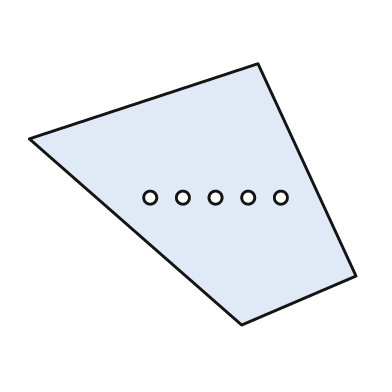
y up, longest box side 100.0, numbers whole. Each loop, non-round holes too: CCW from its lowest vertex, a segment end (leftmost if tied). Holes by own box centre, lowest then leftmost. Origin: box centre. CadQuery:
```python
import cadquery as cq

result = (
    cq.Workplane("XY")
    .moveTo(15.0, -40.0)
    .lineTo(50.0, -25.0)
    .lineTo(20.0, 40.0)
    .lineTo(-50.0, 17.0)
    .close()
    .moveTo(-13.0, -1.0)
    .circle(2.0)
    .moveTo(-3.0, -1.0)
    .circle(2.0)
    .moveTo(7.0, -1.0)
    .circle(2.0)
    .moveTo(17.0, -1.0)
    .circle(2.0)
    .moveTo(27.0, -1.0)
    .circle(2.0)
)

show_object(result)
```